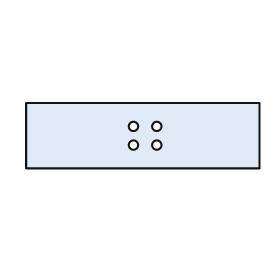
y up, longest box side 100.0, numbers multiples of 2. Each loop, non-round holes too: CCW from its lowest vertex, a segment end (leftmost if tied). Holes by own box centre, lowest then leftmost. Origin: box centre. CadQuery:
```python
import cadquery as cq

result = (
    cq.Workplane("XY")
    .moveTo(-50.0, -14.0)
    .lineTo(50.0, -14.0)
    .lineTo(50.0, 14.0)
    .lineTo(-50.0, 14.0)
    .close()
    .moveTo(-4.0, -4.0)
    .circle(2.0)
    .moveTo(6.0, -4.0)
    .circle(2.0)
    .moveTo(-4.0, 4.0)
    .circle(2.0)
    .moveTo(6.0, 4.0)
    .circle(2.0)
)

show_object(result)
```